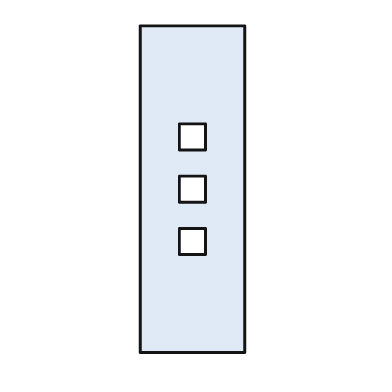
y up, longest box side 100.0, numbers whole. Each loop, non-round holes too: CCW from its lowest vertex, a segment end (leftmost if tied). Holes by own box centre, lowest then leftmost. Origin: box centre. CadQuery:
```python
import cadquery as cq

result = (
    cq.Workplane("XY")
    .moveTo(-16.0, -50.0)
    .lineTo(16.0, -50.0)
    .lineTo(16.0, 50.0)
    .lineTo(-16.0, 50.0)
    .close()
    .moveTo(-4.0, -20.0)
    .lineTo(4.0, -20.0)
    .lineTo(4.0, -12.0)
    .lineTo(-4.0, -12.0)
    .close()
    .moveTo(-4.0, -4.0)
    .lineTo(4.0, -4.0)
    .lineTo(4.0, 4.0)
    .lineTo(-4.0, 4.0)
    .close()
    .moveTo(-4.0, 12.0)
    .lineTo(4.0, 12.0)
    .lineTo(4.0, 20.0)
    .lineTo(-4.0, 20.0)
    .close()
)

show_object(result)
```